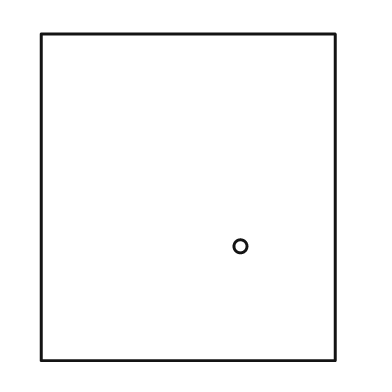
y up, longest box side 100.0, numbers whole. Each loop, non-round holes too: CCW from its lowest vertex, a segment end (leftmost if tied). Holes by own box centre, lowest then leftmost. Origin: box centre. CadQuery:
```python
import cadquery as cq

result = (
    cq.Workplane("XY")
    .moveTo(-45.0, -50.0)
    .lineTo(45.0, -50.0)
    .lineTo(45.0, 50.0)
    .lineTo(-45.0, 50.0)
    .close()
    .moveTo(16.0, -15.0)
    .circle(2.0)
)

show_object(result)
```